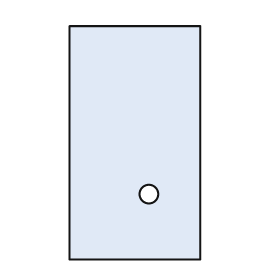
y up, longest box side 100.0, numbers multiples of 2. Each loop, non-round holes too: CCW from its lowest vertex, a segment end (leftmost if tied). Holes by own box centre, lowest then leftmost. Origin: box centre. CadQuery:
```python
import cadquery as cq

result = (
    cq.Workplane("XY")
    .moveTo(-28.0, -50.0)
    .lineTo(28.0, -50.0)
    .lineTo(28.0, 50.0)
    .lineTo(-28.0, 50.0)
    .close()
    .moveTo(6.0, -22.0)
    .circle(4.0)
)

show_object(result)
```